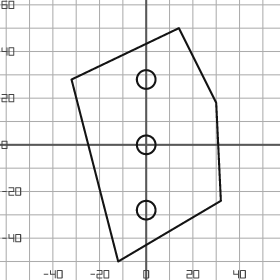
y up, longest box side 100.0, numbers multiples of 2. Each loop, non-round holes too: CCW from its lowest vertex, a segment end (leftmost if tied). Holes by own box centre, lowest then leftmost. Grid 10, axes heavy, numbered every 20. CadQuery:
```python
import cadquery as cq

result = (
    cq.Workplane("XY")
    .moveTo(-12.0, -50.0)
    .lineTo(32.0, -24.0)
    .lineTo(30.0, 18.0)
    .lineTo(14.0, 50.0)
    .lineTo(-32.0, 28.0)
    .close()
    .moveTo(0.0, -28.0)
    .circle(4.0)
    .moveTo(0.0, 0.0)
    .circle(4.0)
    .moveTo(0.0, 28.0)
    .circle(4.0)
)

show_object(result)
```